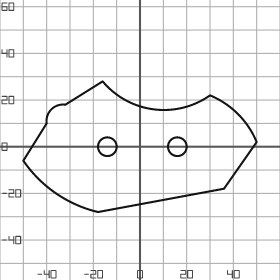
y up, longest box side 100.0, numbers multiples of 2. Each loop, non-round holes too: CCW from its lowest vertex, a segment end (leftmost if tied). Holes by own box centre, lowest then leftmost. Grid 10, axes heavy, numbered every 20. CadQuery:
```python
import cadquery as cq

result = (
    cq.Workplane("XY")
    .moveTo(-18.0, -28.0)
    .lineTo(36.0, -18.0)
    .lineTo(50.0, 2.0)
    .threePointArc((42.0, 14.0), (30.0, 22.0))
    .threePointArc((6.0, 16.0), (-16.0, 28.0))
    .lineTo(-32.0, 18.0)
    .threePointArc((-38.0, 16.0), (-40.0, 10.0))
    .lineTo(-50.0, -6.0)
    .threePointArc((-36.0, -20.0), (-18.0, -28.0))
    .close()
    .moveTo(-14.0, 0.0)
    .circle(4.0)
    .moveTo(16.0, 0.0)
    .circle(4.0)
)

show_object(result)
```